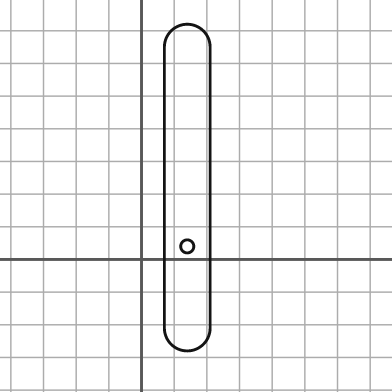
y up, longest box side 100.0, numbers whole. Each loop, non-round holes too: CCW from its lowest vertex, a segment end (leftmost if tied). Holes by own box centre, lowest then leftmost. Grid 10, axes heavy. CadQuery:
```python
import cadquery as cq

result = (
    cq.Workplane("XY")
    .moveTo(7.0, -21.0)
    .threePointArc((14.0, -28.0), (21.0, -21.0))
    .lineTo(21.0, 65.0)
    .threePointArc((14.0, 72.0), (7.0, 65.0))
    .close()
    .moveTo(14.0, 4.0)
    .circle(2.0)
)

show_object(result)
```